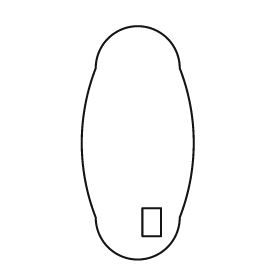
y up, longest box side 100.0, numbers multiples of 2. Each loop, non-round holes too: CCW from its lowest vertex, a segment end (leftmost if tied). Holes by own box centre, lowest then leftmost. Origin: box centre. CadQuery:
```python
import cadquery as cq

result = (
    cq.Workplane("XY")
    .moveTo(-18.0, -32.0)
    .threePointArc((0.0, -50.0), (18.0, -32.0))
    .threePointArc((24.0, 0.0), (18.0, 32.0))
    .threePointArc((0.0, 50.0), (-18.0, 32.0))
    .threePointArc((-24.0, 0.0), (-18.0, -32.0))
    .close()
    .moveTo(2.0, -40.0)
    .lineTo(10.0, -40.0)
    .lineTo(10.0, -28.0)
    .lineTo(2.0, -28.0)
    .close()
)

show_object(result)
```